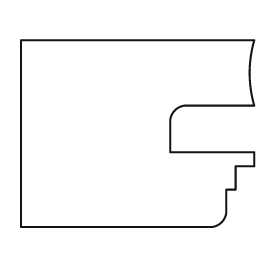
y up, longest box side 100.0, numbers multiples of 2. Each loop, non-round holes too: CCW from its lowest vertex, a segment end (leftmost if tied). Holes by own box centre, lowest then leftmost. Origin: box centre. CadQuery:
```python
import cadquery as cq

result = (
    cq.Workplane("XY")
    .moveTo(-50.0, -40.0)
    .lineTo(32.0, -40.0)
    .threePointArc((36.0, -38.0), (38.0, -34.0))
    .lineTo(38.0, -24.0)
    .lineTo(42.0, -24.0)
    .lineTo(42.0, -14.0)
    .lineTo(50.0, -14.0)
    .lineTo(50.0, -8.0)
    .lineTo(14.0, -8.0)
    .lineTo(14.0, 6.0)
    .threePointArc((16.0, 10.0), (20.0, 12.0))
    .lineTo(50.0, 12.0)
    .threePointArc((48.0, 26.0), (50.0, 40.0))
    .lineTo(-50.0, 40.0)
    .close()
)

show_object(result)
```